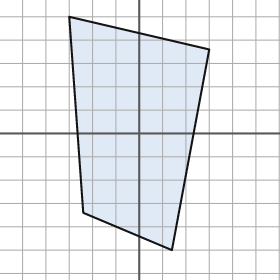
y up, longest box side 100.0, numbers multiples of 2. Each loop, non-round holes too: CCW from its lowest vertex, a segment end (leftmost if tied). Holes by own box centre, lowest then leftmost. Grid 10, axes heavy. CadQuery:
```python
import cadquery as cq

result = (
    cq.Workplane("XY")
    .moveTo(14.0, -50.0)
    .lineTo(30.0, 36.0)
    .lineTo(-30.0, 50.0)
    .lineTo(-24.0, -34.0)
    .close()
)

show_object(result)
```